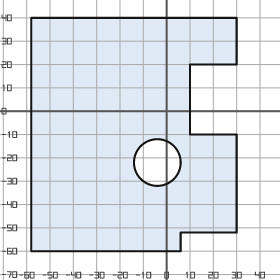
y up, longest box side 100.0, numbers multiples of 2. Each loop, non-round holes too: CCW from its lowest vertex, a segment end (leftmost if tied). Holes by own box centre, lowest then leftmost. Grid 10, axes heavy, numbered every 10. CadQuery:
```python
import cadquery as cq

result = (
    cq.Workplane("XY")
    .moveTo(-58.0, -60.0)
    .lineTo(6.0, -60.0)
    .lineTo(6.0, -52.0)
    .lineTo(30.0, -52.0)
    .lineTo(30.0, -10.0)
    .lineTo(10.0, -10.0)
    .lineTo(10.0, 20.0)
    .lineTo(30.0, 20.0)
    .lineTo(30.0, 40.0)
    .lineTo(-58.0, 40.0)
    .close()
    .moveTo(-4.0, -22.0)
    .circle(10.0)
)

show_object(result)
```